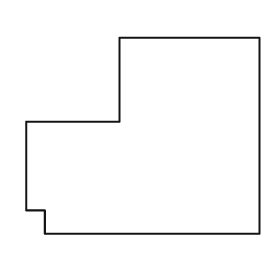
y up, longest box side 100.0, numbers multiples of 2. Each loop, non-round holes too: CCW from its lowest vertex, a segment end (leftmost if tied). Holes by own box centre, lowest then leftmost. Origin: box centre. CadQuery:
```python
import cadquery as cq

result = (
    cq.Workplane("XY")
    .moveTo(-42.0, -42.0)
    .lineTo(50.0, -42.0)
    .lineTo(50.0, 42.0)
    .lineTo(-10.0, 42.0)
    .lineTo(-10.0, 6.0)
    .lineTo(-50.0, 6.0)
    .lineTo(-50.0, -32.0)
    .lineTo(-42.0, -32.0)
    .close()
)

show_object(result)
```